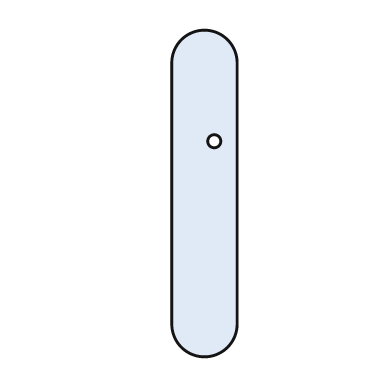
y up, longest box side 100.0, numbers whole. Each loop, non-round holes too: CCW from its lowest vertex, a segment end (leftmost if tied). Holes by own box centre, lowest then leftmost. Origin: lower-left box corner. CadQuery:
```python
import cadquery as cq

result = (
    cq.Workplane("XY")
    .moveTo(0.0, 10.0)
    .threePointArc((10.0, 0.0), (20.0, 10.0))
    .lineTo(20.0, 90.0)
    .threePointArc((10.0, 100.0), (0.0, 90.0))
    .close()
    .moveTo(13.0, 66.0)
    .circle(2.0)
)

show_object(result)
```